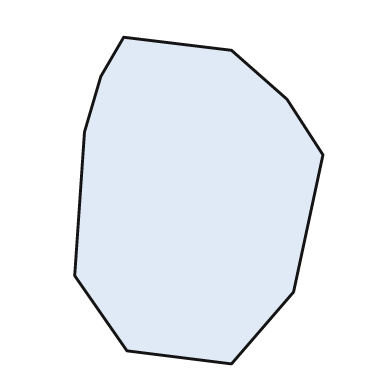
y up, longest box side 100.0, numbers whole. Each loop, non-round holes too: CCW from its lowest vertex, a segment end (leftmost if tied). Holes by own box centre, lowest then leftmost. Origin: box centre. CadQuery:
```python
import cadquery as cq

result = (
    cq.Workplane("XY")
    .moveTo(10.0, -50.0)
    .lineTo(29.0, -28.0)
    .lineTo(38.0, 14.0)
    .lineTo(27.0, 31.0)
    .lineTo(10.0, 46.0)
    .lineTo(-23.0, 50.0)
    .lineTo(-30.0, 38.0)
    .lineTo(-35.0, 21.0)
    .lineTo(-38.0, -23.0)
    .lineTo(-22.0, -46.0)
    .close()
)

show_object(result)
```